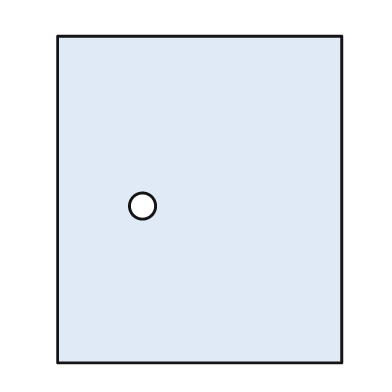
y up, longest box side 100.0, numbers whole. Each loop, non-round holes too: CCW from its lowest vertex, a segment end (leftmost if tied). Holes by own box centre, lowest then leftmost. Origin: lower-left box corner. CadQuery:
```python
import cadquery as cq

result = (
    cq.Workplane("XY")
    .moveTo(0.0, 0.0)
    .lineTo(87.0, 0.0)
    .lineTo(87.0, 100.0)
    .lineTo(0.0, 100.0)
    .close()
    .moveTo(26.0, 48.0)
    .circle(4.0)
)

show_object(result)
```